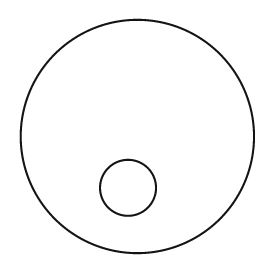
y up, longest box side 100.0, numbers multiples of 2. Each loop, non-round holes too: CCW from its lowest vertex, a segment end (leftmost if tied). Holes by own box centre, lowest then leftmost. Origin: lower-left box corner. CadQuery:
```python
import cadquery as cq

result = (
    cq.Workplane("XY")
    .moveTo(50.0, 50.0)
    .circle(50.0)
    .moveTo(46.0, 28.0)
    .circle(12.0)
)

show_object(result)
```